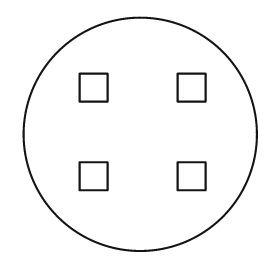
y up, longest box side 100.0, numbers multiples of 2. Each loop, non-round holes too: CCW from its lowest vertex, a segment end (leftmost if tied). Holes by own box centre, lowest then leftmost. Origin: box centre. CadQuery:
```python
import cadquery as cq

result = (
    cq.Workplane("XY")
    .moveTo(0.0, 0.0)
    .circle(50.0)
    .moveTo(-26.0, -24.0)
    .lineTo(-14.0, -24.0)
    .lineTo(-14.0, -12.0)
    .lineTo(-26.0, -12.0)
    .close()
    .moveTo(16.0, -24.0)
    .lineTo(28.0, -24.0)
    .lineTo(28.0, -12.0)
    .lineTo(16.0, -12.0)
    .close()
    .moveTo(-26.0, 14.0)
    .lineTo(-14.0, 14.0)
    .lineTo(-14.0, 26.0)
    .lineTo(-26.0, 26.0)
    .close()
    .moveTo(16.0, 14.0)
    .lineTo(28.0, 14.0)
    .lineTo(28.0, 26.0)
    .lineTo(16.0, 26.0)
    .close()
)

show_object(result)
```